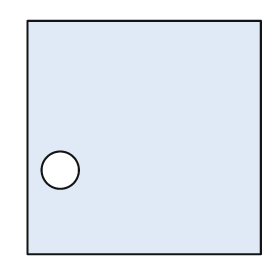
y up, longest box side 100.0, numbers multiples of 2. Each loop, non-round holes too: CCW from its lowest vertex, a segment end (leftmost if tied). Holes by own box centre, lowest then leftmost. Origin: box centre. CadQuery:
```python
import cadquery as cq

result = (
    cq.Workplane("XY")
    .moveTo(-50.0, -50.0)
    .lineTo(50.0, -50.0)
    .lineTo(50.0, 50.0)
    .lineTo(-50.0, 50.0)
    .close()
    .moveTo(-36.0, -14.0)
    .circle(8.0)
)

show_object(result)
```